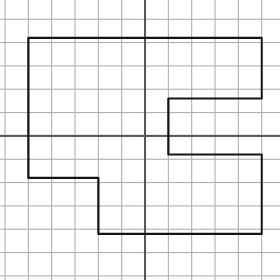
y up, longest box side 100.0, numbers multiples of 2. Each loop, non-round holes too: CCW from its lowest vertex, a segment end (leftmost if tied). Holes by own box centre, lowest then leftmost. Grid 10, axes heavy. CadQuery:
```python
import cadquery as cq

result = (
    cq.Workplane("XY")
    .moveTo(-20.0, -42.0)
    .lineTo(50.0, -42.0)
    .lineTo(50.0, -8.0)
    .lineTo(10.0, -8.0)
    .lineTo(10.0, 16.0)
    .lineTo(50.0, 16.0)
    .lineTo(50.0, 42.0)
    .lineTo(-50.0, 42.0)
    .lineTo(-50.0, -18.0)
    .lineTo(-20.0, -18.0)
    .close()
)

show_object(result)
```